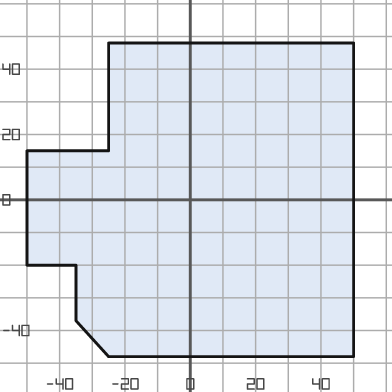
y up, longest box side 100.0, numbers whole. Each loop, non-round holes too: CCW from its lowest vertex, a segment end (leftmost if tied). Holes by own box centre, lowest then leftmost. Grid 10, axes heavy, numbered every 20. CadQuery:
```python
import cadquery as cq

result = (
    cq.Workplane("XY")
    .moveTo(-25.0, -48.0)
    .lineTo(50.0, -48.0)
    .lineTo(50.0, 48.0)
    .lineTo(-25.0, 48.0)
    .lineTo(-25.0, 15.0)
    .lineTo(-50.0, 15.0)
    .lineTo(-50.0, -20.0)
    .lineTo(-35.0, -20.0)
    .lineTo(-35.0, -37.0)
    .close()
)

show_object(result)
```